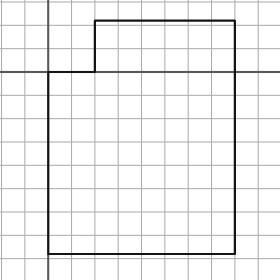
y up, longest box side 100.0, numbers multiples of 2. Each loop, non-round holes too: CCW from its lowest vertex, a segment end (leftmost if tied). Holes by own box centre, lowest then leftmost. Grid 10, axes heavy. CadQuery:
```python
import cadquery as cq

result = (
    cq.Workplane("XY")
    .moveTo(0.0, -78.0)
    .lineTo(80.0, -78.0)
    .lineTo(80.0, 22.0)
    .lineTo(20.0, 22.0)
    .lineTo(20.0, 0.0)
    .lineTo(0.0, 0.0)
    .close()
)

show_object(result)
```